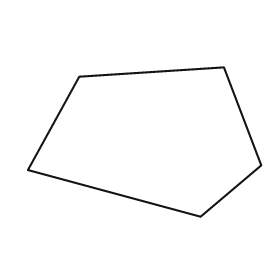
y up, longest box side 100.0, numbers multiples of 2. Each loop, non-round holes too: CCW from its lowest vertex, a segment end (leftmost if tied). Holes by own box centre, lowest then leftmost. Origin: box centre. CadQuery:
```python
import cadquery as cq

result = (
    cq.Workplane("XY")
    .moveTo(24.0, -32.0)
    .lineTo(50.0, -10.0)
    .lineTo(34.0, 32.0)
    .lineTo(-28.0, 28.0)
    .lineTo(-50.0, -12.0)
    .close()
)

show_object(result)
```